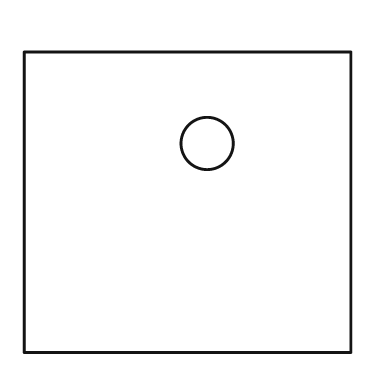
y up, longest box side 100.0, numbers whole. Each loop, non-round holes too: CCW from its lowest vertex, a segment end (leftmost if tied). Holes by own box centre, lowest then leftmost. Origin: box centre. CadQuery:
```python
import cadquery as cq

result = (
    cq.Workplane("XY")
    .moveTo(-50.0, -46.0)
    .lineTo(50.0, -46.0)
    .lineTo(50.0, 46.0)
    .lineTo(-50.0, 46.0)
    .close()
    .moveTo(6.0, 18.0)
    .circle(8.0)
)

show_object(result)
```